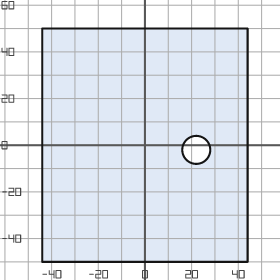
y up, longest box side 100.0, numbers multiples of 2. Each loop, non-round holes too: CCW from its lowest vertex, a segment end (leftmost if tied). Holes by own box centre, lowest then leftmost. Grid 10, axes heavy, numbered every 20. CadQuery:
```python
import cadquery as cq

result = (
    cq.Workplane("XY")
    .moveTo(-44.0, -50.0)
    .lineTo(44.0, -50.0)
    .lineTo(44.0, 50.0)
    .lineTo(-44.0, 50.0)
    .close()
    .moveTo(22.0, -2.0)
    .circle(6.0)
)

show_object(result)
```